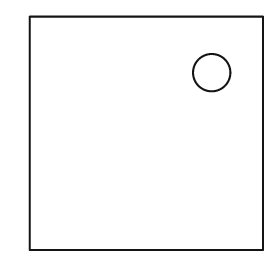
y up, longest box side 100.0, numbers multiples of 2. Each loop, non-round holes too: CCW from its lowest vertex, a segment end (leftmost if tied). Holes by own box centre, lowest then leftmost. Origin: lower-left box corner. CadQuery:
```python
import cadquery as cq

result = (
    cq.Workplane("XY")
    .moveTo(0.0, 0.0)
    .lineTo(100.0, 0.0)
    .lineTo(100.0, 100.0)
    .lineTo(0.0, 100.0)
    .close()
    .moveTo(78.0, 76.0)
    .circle(8.0)
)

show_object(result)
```